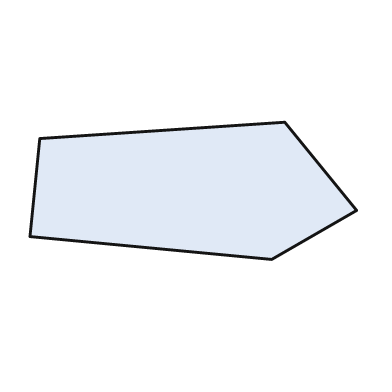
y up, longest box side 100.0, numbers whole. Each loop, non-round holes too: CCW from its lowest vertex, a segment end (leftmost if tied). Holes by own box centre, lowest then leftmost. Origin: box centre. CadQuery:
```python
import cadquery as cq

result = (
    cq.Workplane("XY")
    .moveTo(24.0, -21.0)
    .lineTo(50.0, -6.0)
    .lineTo(28.0, 21.0)
    .lineTo(-47.0, 16.0)
    .lineTo(-50.0, -14.0)
    .close()
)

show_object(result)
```